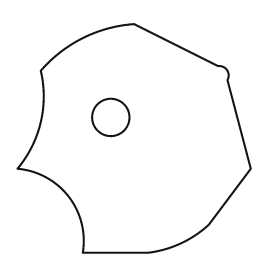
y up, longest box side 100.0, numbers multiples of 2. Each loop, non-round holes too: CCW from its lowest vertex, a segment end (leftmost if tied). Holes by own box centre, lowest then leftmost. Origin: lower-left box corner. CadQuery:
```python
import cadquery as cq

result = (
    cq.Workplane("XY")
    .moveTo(28.0, 0.0)
    .lineTo(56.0, 0.0)
    .threePointArc((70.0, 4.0), (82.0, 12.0))
    .lineTo(100.0, 36.0)
    .lineTo(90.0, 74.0)
    .threePointArc((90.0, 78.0), (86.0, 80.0))
    .lineTo(50.0, 98.0)
    .threePointArc((28.0, 92.0), (10.0, 78.0))
    .threePointArc((10.0, 56.0), (0.0, 36.0))
    .threePointArc((22.0, 24.0), (28.0, 0.0))
    .close()
    .moveTo(40.0, 58.0)
    .circle(8.0)
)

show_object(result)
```